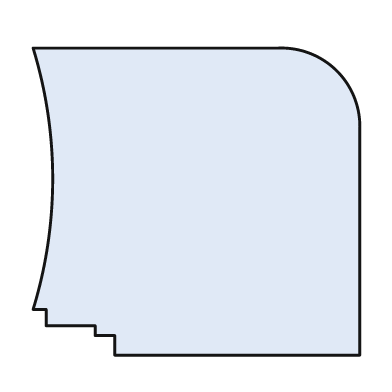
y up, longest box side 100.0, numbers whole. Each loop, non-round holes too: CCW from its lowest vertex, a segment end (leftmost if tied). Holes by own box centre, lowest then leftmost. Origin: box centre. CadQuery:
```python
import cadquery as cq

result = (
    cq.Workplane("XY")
    .moveTo(-25.0, -47.0)
    .lineTo(50.0, -47.0)
    .lineTo(50.0, 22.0)
    .threePointArc((43.0, 40.0), (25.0, 47.0))
    .lineTo(-50.0, 47.0)
    .threePointArc((-44.0, 7.0), (-50.0, -33.0))
    .lineTo(-46.0, -33.0)
    .lineTo(-46.0, -38.0)
    .lineTo(-31.0, -38.0)
    .lineTo(-31.0, -41.0)
    .lineTo(-25.0, -41.0)
    .close()
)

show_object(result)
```